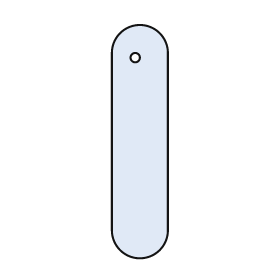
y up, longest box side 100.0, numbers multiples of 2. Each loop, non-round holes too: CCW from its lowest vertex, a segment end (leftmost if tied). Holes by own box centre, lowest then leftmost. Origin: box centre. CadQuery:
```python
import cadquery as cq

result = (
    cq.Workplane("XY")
    .moveTo(-12.0, -38.0)
    .threePointArc((0.0, -50.0), (12.0, -38.0))
    .lineTo(12.0, 38.0)
    .threePointArc((0.0, 50.0), (-12.0, 38.0))
    .close()
    .moveTo(-2.0, 36.0)
    .circle(2.0)
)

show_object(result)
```